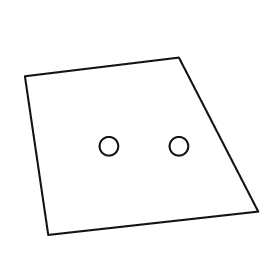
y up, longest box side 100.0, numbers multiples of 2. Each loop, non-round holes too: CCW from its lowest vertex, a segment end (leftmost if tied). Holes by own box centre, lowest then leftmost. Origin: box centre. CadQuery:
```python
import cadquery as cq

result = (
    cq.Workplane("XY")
    .moveTo(-40.0, -38.0)
    .lineTo(50.0, -28.0)
    .lineTo(16.0, 38.0)
    .lineTo(-50.0, 30.0)
    .close()
    .moveTo(-14.0, 0.0)
    .circle(4.0)
    .moveTo(16.0, 0.0)
    .circle(4.0)
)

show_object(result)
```